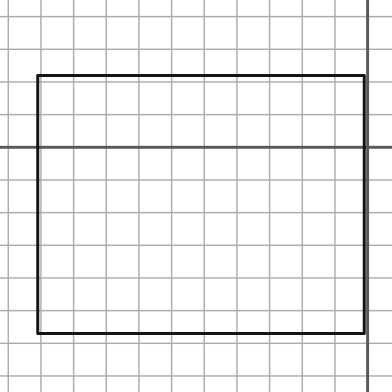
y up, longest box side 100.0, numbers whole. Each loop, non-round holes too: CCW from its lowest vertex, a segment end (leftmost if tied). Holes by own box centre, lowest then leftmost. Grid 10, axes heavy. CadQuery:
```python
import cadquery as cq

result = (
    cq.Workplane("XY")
    .moveTo(-101.0, -57.0)
    .lineTo(-1.0, -57.0)
    .lineTo(-1.0, 22.0)
    .lineTo(-101.0, 22.0)
    .close()
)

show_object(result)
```